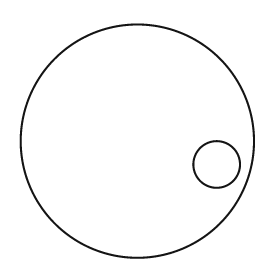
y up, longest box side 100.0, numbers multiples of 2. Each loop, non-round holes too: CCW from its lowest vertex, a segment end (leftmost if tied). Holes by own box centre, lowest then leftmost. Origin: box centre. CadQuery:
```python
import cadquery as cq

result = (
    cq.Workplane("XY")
    .moveTo(0.0, 0.0)
    .circle(50.0)
    .moveTo(34.0, -10.0)
    .circle(10.0)
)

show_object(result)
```